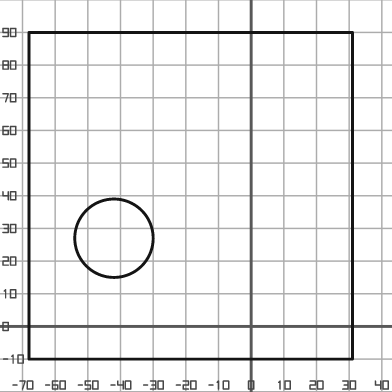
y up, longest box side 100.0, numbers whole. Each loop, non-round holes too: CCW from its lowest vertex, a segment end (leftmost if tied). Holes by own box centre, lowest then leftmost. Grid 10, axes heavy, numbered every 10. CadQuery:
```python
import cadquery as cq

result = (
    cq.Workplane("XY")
    .moveTo(-68.0, -10.0)
    .lineTo(31.0, -10.0)
    .lineTo(31.0, 90.0)
    .lineTo(-68.0, 90.0)
    .close()
    .moveTo(-42.0, 27.0)
    .circle(12.0)
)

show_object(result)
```